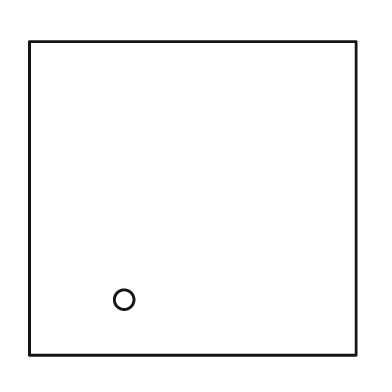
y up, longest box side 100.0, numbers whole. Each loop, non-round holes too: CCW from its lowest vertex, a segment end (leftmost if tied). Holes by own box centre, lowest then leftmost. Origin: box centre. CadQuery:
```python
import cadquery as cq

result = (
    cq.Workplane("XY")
    .moveTo(-50.0, -48.0)
    .lineTo(50.0, -48.0)
    .lineTo(50.0, 48.0)
    .lineTo(-50.0, 48.0)
    .close()
    .moveTo(-21.0, -31.0)
    .circle(3.0)
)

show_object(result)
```